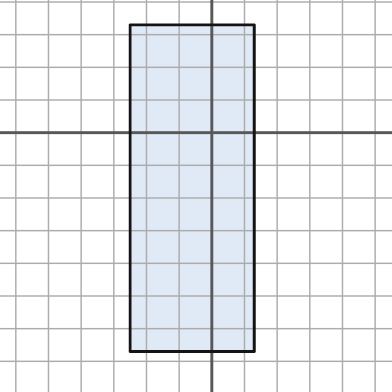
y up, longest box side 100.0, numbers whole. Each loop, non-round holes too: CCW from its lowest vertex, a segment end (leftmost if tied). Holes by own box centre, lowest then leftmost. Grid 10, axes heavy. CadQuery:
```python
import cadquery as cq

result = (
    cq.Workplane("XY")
    .moveTo(-25.0, -67.0)
    .lineTo(13.0, -67.0)
    .lineTo(13.0, 33.0)
    .lineTo(-25.0, 33.0)
    .close()
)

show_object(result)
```